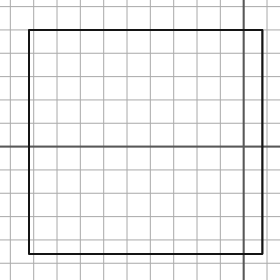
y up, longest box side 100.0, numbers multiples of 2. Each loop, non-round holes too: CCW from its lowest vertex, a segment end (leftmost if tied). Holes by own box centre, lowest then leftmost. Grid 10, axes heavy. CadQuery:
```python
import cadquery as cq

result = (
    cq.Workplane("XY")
    .moveTo(-92.0, -46.0)
    .lineTo(8.0, -46.0)
    .lineTo(8.0, 50.0)
    .lineTo(-92.0, 50.0)
    .close()
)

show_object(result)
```